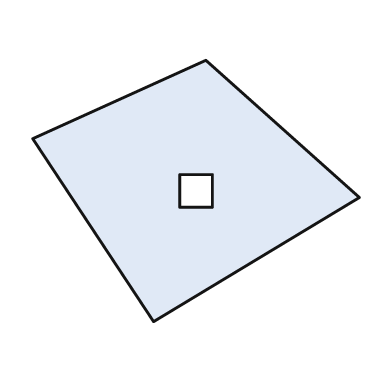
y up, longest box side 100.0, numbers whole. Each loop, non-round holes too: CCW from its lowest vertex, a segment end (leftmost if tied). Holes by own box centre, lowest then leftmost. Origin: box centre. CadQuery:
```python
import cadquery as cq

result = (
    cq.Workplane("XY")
    .moveTo(-13.0, -40.0)
    .lineTo(50.0, -2.0)
    .lineTo(3.0, 40.0)
    .lineTo(-50.0, 16.0)
    .close()
    .moveTo(-5.0, -5.0)
    .lineTo(5.0, -5.0)
    .lineTo(5.0, 5.0)
    .lineTo(-5.0, 5.0)
    .close()
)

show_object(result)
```